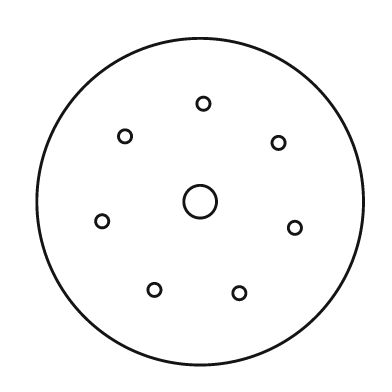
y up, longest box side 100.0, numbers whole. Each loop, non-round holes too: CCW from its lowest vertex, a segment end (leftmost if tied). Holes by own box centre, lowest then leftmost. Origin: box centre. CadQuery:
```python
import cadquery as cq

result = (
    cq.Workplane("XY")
    .moveTo(0.0, 0.0)
    .circle(50.0)
    .moveTo(12.0, -28.0)
    .circle(2.0)
    .moveTo(-14.0, -27.0)
    .circle(2.0)
    .moveTo(29.0, -8.0)
    .circle(2.0)
    .moveTo(-30.0, -6.0)
    .circle(2.0)
    .moveTo(0.0, 0.0)
    .circle(5.0)
    .moveTo(24.0, 18.0)
    .circle(2.0)
    .moveTo(-23.0, 20.0)
    .circle(2.0)
    .moveTo(1.0, 30.0)
    .circle(2.0)
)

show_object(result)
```